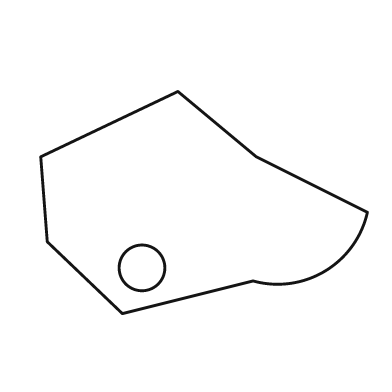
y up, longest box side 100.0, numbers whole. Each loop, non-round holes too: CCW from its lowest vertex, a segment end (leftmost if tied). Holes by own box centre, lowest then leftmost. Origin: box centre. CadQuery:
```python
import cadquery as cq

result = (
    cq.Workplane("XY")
    .moveTo(-25.0, -34.0)
    .lineTo(15.0, -24.0)
    .threePointArc((37.0, -21.0), (50.0, -3.0))
    .lineTo(16.0, 14.0)
    .lineTo(-8.0, 34.0)
    .lineTo(-50.0, 14.0)
    .lineTo(-48.0, -12.0)
    .close()
    .moveTo(-19.0, -20.0)
    .circle(7.0)
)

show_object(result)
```